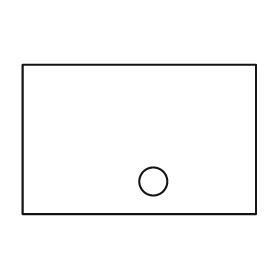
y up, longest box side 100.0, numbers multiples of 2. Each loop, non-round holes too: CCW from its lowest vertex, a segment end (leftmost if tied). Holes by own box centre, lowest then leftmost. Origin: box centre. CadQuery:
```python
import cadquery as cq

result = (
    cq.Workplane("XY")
    .moveTo(-50.0, -32.0)
    .lineTo(50.0, -32.0)
    .lineTo(50.0, 32.0)
    .lineTo(-50.0, 32.0)
    .close()
    .moveTo(6.0, -18.0)
    .circle(6.0)
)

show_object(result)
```